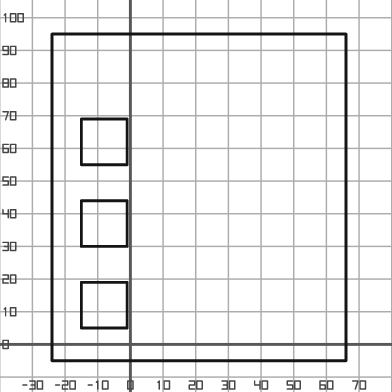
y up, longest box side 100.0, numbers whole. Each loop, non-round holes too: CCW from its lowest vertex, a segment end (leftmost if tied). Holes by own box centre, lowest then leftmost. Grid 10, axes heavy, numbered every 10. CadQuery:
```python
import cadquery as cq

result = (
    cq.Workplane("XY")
    .moveTo(-24.0, -5.0)
    .lineTo(66.0, -5.0)
    .lineTo(66.0, 95.0)
    .lineTo(-24.0, 95.0)
    .close()
    .moveTo(-15.0, 5.0)
    .lineTo(-1.0, 5.0)
    .lineTo(-1.0, 19.0)
    .lineTo(-15.0, 19.0)
    .close()
    .moveTo(-15.0, 30.0)
    .lineTo(-1.0, 30.0)
    .lineTo(-1.0, 44.0)
    .lineTo(-15.0, 44.0)
    .close()
    .moveTo(-15.0, 55.0)
    .lineTo(-1.0, 55.0)
    .lineTo(-1.0, 69.0)
    .lineTo(-15.0, 69.0)
    .close()
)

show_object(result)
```